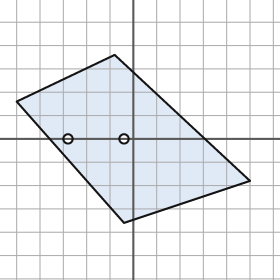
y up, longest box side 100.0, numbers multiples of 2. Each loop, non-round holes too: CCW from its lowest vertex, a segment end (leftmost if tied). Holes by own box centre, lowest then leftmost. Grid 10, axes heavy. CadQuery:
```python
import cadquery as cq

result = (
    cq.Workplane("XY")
    .moveTo(-4.0, -36.0)
    .lineTo(50.0, -18.0)
    .lineTo(-8.0, 36.0)
    .lineTo(-50.0, 16.0)
    .close()
    .moveTo(-28.0, 0.0)
    .circle(2.0)
    .moveTo(-4.0, 0.0)
    .circle(2.0)
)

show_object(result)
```